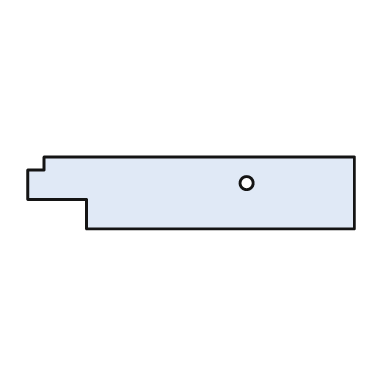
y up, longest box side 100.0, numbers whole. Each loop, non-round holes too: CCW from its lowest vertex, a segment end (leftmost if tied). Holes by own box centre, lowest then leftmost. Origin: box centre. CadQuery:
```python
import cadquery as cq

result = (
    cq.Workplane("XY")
    .moveTo(-32.0, -11.0)
    .lineTo(50.0, -11.0)
    .lineTo(50.0, 11.0)
    .lineTo(-45.0, 11.0)
    .lineTo(-45.0, 7.0)
    .lineTo(-50.0, 7.0)
    .lineTo(-50.0, -2.0)
    .lineTo(-32.0, -2.0)
    .close()
    .moveTo(17.0, 3.0)
    .circle(2.0)
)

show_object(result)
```